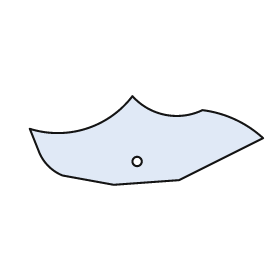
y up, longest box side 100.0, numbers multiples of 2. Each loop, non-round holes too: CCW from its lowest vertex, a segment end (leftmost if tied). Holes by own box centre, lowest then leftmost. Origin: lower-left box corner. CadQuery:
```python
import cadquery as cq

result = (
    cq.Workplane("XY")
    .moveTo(36.0, 0.0)
    .lineTo(64.0, 2.0)
    .lineTo(100.0, 20.0)
    .threePointArc((88.0, 28.0), (74.0, 32.0))
    .threePointArc((58.0, 30.0), (44.0, 38.0))
    .threePointArc((24.0, 24.0), (0.0, 24.0))
    .lineTo(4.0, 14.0)
    .threePointArc((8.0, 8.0), (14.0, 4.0))
    .close()
    .moveTo(46.0, 10.0)
    .circle(2.0)
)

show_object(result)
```